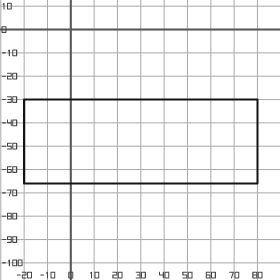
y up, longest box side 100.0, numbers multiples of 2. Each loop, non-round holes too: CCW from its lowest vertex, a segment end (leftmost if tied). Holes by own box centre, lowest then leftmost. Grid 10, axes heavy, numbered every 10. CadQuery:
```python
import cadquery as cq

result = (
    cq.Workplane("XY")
    .moveTo(-20.0, -66.0)
    .lineTo(80.0, -66.0)
    .lineTo(80.0, -30.0)
    .lineTo(-20.0, -30.0)
    .close()
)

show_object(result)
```